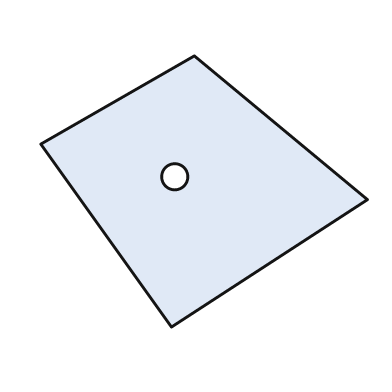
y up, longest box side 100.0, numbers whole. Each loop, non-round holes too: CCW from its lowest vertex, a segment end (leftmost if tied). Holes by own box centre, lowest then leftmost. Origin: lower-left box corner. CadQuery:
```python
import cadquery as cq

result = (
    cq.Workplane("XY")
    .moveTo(40.0, 0.0)
    .lineTo(100.0, 39.0)
    .lineTo(47.0, 83.0)
    .lineTo(0.0, 56.0)
    .close()
    .moveTo(41.0, 46.0)
    .circle(4.0)
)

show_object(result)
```